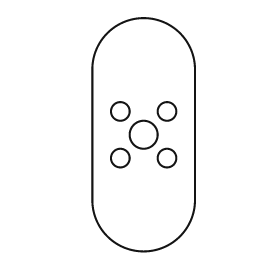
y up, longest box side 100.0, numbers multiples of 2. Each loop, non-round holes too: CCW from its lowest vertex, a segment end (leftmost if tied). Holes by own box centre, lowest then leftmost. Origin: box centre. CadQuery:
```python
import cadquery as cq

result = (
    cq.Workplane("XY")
    .moveTo(-22.0, -28.0)
    .threePointArc((0.0, -50.0), (22.0, -28.0))
    .lineTo(22.0, 28.0)
    .threePointArc((0.0, 50.0), (-22.0, 28.0))
    .close()
    .moveTo(-10.0, -10.0)
    .circle(4.0)
    .moveTo(10.0, -10.0)
    .circle(4.0)
    .moveTo(0.0, 0.0)
    .circle(6.0)
    .moveTo(-10.0, 10.0)
    .circle(4.0)
    .moveTo(10.0, 10.0)
    .circle(4.0)
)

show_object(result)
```